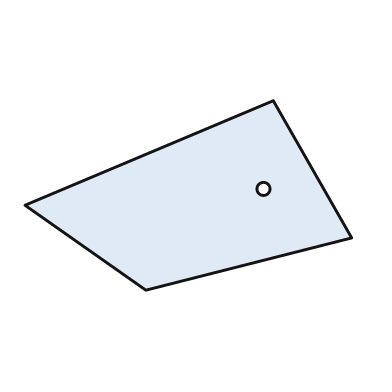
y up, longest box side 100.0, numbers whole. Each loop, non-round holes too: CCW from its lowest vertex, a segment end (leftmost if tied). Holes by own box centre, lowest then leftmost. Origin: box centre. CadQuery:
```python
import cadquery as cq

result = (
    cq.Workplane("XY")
    .moveTo(-13.0, -29.0)
    .lineTo(50.0, -13.0)
    .lineTo(26.0, 29.0)
    .lineTo(-50.0, -3.0)
    .close()
    .moveTo(23.0, 2.0)
    .circle(2.0)
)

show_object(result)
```